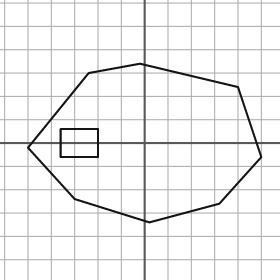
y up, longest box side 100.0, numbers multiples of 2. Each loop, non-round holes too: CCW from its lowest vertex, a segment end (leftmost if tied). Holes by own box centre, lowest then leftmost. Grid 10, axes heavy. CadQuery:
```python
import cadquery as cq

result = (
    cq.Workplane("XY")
    .moveTo(2.0, -34.0)
    .lineTo(32.0, -26.0)
    .lineTo(50.0, -6.0)
    .lineTo(40.0, 24.0)
    .lineTo(-2.0, 34.0)
    .lineTo(-24.0, 30.0)
    .lineTo(-50.0, -2.0)
    .lineTo(-30.0, -24.0)
    .close()
    .moveTo(-36.0, -6.0)
    .lineTo(-20.0, -6.0)
    .lineTo(-20.0, 6.0)
    .lineTo(-36.0, 6.0)
    .close()
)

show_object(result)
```